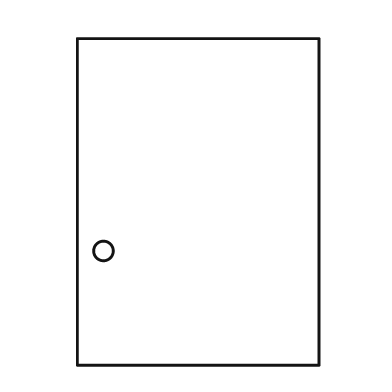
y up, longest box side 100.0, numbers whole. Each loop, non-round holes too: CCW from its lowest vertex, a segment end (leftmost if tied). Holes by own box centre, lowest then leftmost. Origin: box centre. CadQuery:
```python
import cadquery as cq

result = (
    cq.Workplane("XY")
    .moveTo(-37.0, -50.0)
    .lineTo(37.0, -50.0)
    .lineTo(37.0, 50.0)
    .lineTo(-37.0, 50.0)
    .close()
    .moveTo(-29.0, -15.0)
    .circle(3.0)
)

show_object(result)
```